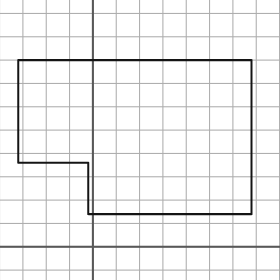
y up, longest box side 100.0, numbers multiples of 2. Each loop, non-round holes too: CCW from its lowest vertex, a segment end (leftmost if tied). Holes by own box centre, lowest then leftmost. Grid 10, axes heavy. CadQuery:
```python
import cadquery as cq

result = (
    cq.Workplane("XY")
    .moveTo(-2.0, 14.0)
    .lineTo(68.0, 14.0)
    .lineTo(68.0, 80.0)
    .lineTo(-32.0, 80.0)
    .lineTo(-32.0, 36.0)
    .lineTo(-2.0, 36.0)
    .close()
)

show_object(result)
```